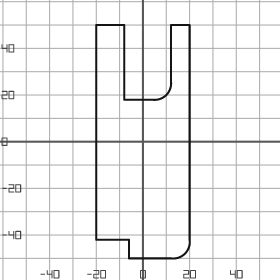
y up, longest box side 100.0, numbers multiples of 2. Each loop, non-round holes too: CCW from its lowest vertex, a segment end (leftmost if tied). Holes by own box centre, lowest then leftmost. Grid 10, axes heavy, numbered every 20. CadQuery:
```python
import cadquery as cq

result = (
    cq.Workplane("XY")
    .moveTo(-6.0, -50.0)
    .lineTo(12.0, -50.0)
    .threePointArc((18.0, -48.0), (20.0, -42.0))
    .lineTo(20.0, 50.0)
    .lineTo(12.0, 50.0)
    .lineTo(12.0, 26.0)
    .threePointArc((10.0, 20.0), (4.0, 18.0))
    .lineTo(-8.0, 18.0)
    .lineTo(-8.0, 50.0)
    .lineTo(-20.0, 50.0)
    .lineTo(-20.0, -42.0)
    .lineTo(-6.0, -42.0)
    .close()
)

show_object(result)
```